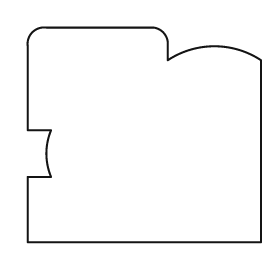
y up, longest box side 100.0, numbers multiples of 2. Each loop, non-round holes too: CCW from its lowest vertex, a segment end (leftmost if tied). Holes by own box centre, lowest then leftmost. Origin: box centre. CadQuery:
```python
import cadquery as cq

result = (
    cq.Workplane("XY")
    .moveTo(-50.0, -46.0)
    .lineTo(50.0, -46.0)
    .lineTo(50.0, 32.0)
    .threePointArc((30.0, 38.0), (10.0, 32.0))
    .lineTo(10.0, 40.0)
    .threePointArc((8.0, 44.0), (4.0, 46.0))
    .lineTo(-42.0, 46.0)
    .threePointArc((-48.0, 44.0), (-50.0, 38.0))
    .lineTo(-50.0, 2.0)
    .lineTo(-40.0, 2.0)
    .threePointArc((-42.0, -8.0), (-40.0, -18.0))
    .lineTo(-50.0, -18.0)
    .close()
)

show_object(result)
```